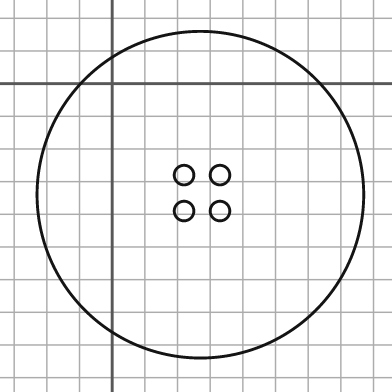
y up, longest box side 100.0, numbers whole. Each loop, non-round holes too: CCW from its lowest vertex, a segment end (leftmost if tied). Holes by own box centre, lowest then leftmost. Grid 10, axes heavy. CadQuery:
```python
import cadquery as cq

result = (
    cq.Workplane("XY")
    .moveTo(27.0, -34.0)
    .circle(50.0)
    .moveTo(22.0, -39.0)
    .circle(3.0)
    .moveTo(33.0, -39.0)
    .circle(3.0)
    .moveTo(22.0, -28.0)
    .circle(3.0)
    .moveTo(33.0, -28.0)
    .circle(3.0)
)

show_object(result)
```